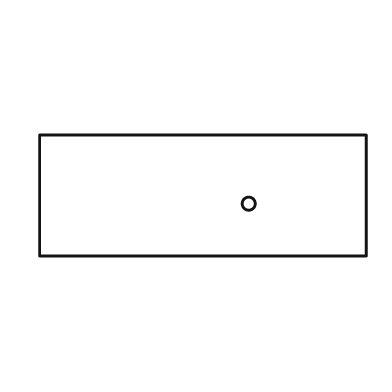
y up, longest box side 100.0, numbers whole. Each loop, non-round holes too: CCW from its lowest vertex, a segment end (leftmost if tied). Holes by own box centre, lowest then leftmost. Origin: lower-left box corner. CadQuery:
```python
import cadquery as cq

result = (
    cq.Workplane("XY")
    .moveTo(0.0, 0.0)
    .lineTo(100.0, 0.0)
    .lineTo(100.0, 37.0)
    .lineTo(0.0, 37.0)
    .close()
    .moveTo(64.0, 16.0)
    .circle(2.0)
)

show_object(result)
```